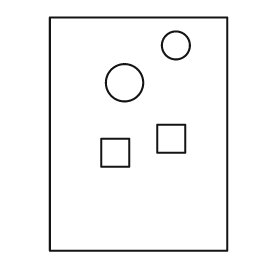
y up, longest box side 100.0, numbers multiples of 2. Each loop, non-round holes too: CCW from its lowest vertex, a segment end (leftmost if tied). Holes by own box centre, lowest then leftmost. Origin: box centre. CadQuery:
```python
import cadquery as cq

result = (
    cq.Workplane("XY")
    .moveTo(-38.0, -50.0)
    .lineTo(38.0, -50.0)
    .lineTo(38.0, 50.0)
    .lineTo(-38.0, 50.0)
    .close()
    .moveTo(-16.0, -14.0)
    .lineTo(-4.0, -14.0)
    .lineTo(-4.0, -2.0)
    .lineTo(-16.0, -2.0)
    .close()
    .moveTo(8.0, -8.0)
    .lineTo(20.0, -8.0)
    .lineTo(20.0, 4.0)
    .lineTo(8.0, 4.0)
    .close()
    .moveTo(-6.0, 22.0)
    .circle(8.0)
    .moveTo(16.0, 38.0)
    .circle(6.0)
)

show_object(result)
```